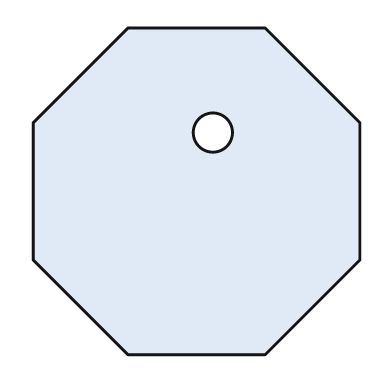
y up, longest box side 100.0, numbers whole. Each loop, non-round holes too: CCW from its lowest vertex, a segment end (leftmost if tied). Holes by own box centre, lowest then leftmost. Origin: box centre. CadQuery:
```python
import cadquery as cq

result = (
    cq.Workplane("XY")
    .moveTo(-21.0, -50.0)
    .lineTo(21.0, -50.0)
    .lineTo(50.0, -21.0)
    .lineTo(50.0, 21.0)
    .lineTo(21.0, 50.0)
    .lineTo(-21.0, 50.0)
    .lineTo(-50.0, 21.0)
    .lineTo(-50.0, -21.0)
    .close()
    .moveTo(5.0, 18.0)
    .circle(6.0)
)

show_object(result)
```